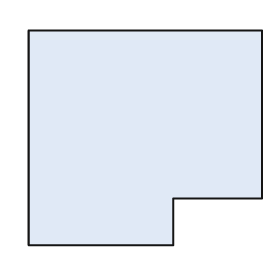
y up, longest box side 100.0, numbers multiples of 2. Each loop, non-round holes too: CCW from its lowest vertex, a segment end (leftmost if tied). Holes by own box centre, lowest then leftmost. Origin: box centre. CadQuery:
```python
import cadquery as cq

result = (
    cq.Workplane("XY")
    .moveTo(-50.0, -46.0)
    .lineTo(12.0, -46.0)
    .lineTo(12.0, -26.0)
    .lineTo(50.0, -26.0)
    .lineTo(50.0, 46.0)
    .lineTo(-50.0, 46.0)
    .close()
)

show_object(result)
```